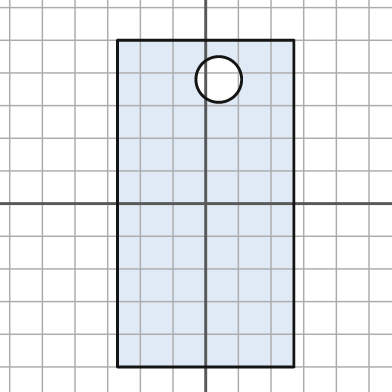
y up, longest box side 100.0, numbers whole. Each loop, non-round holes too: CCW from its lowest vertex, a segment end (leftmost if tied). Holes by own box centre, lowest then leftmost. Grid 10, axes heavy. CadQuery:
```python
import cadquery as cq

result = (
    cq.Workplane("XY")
    .moveTo(-27.0, -50.0)
    .lineTo(27.0, -50.0)
    .lineTo(27.0, 50.0)
    .lineTo(-27.0, 50.0)
    .close()
    .moveTo(4.0, 38.0)
    .circle(7.0)
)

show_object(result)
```